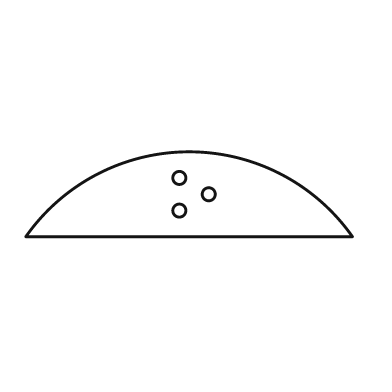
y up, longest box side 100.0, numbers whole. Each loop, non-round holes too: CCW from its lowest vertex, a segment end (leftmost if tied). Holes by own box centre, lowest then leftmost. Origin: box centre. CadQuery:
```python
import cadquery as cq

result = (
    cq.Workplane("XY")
    .moveTo(-50.0, -13.0)
    .lineTo(50.0, -13.0)
    .threePointArc((0.0, 13.0), (-50.0, -13.0))
    .close()
    .moveTo(-3.0, -5.0)
    .circle(2.0)
    .moveTo(6.0, 0.0)
    .circle(2.0)
    .moveTo(-3.0, 5.0)
    .circle(2.0)
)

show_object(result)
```